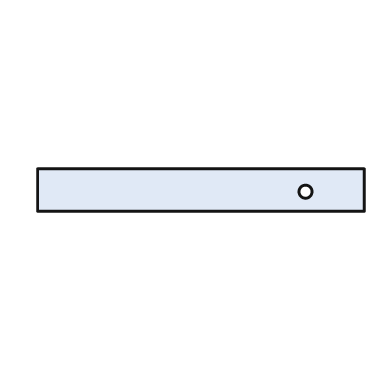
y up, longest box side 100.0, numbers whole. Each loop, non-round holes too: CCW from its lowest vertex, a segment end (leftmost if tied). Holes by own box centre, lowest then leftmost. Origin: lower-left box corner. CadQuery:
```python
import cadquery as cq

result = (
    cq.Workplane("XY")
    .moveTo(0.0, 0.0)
    .lineTo(100.0, 0.0)
    .lineTo(100.0, 13.0)
    .lineTo(0.0, 13.0)
    .close()
    .moveTo(82.0, 6.0)
    .circle(2.0)
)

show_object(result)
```